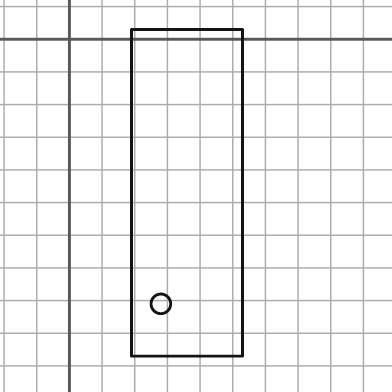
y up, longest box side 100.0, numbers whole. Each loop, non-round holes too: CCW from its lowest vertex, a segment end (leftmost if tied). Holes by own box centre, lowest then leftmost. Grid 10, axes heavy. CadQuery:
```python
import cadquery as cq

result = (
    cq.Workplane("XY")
    .moveTo(19.0, -97.0)
    .lineTo(53.0, -97.0)
    .lineTo(53.0, 3.0)
    .lineTo(19.0, 3.0)
    .close()
    .moveTo(28.0, -81.0)
    .circle(3.0)
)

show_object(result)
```